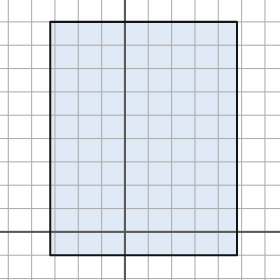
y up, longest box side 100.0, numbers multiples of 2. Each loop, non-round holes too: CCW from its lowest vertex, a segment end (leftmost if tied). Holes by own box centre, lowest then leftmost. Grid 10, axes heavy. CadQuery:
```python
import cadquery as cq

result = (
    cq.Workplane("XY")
    .moveTo(-32.0, -10.0)
    .lineTo(48.0, -10.0)
    .lineTo(48.0, 90.0)
    .lineTo(-32.0, 90.0)
    .close()
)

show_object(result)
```